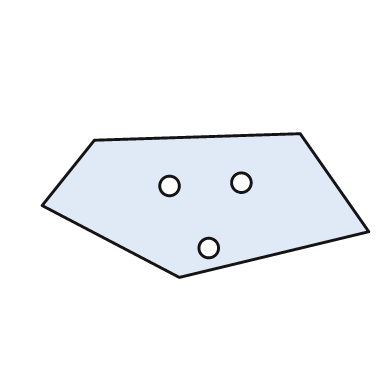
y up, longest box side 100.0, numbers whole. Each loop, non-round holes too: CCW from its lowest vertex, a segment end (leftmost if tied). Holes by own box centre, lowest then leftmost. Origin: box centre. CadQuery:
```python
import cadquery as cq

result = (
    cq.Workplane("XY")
    .moveTo(-8.0, -22.0)
    .lineTo(50.0, -8.0)
    .lineTo(29.0, 22.0)
    .lineTo(-34.0, 20.0)
    .lineTo(-50.0, 0.0)
    .close()
    .moveTo(1.0, -13.0)
    .circle(3.0)
    .moveTo(-11.0, 6.0)
    .circle(3.0)
    .moveTo(11.0, 7.0)
    .circle(3.0)
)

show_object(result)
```